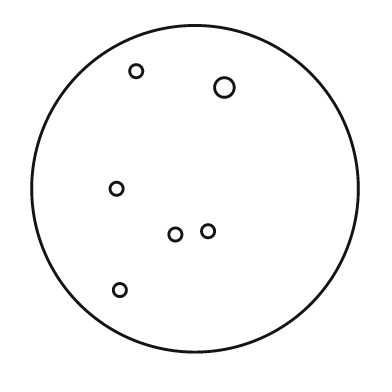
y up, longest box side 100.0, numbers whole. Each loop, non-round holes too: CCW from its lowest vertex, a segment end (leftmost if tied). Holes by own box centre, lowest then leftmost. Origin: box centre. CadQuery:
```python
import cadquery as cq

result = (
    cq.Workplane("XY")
    .moveTo(0.0, 0.0)
    .circle(50.0)
    .moveTo(-23.0, -31.0)
    .circle(2.0)
    .moveTo(-6.0, -14.0)
    .circle(2.0)
    .moveTo(4.0, -13.0)
    .circle(2.0)
    .moveTo(-24.0, 0.0)
    .circle(2.0)
    .moveTo(9.0, 31.0)
    .circle(3.0)
    .moveTo(-18.0, 36.0)
    .circle(2.0)
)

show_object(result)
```